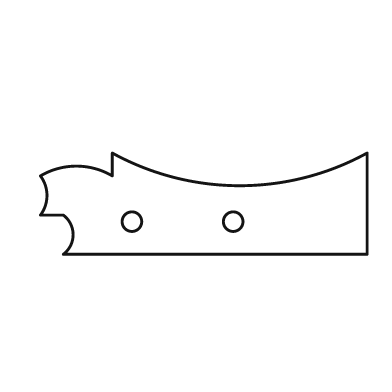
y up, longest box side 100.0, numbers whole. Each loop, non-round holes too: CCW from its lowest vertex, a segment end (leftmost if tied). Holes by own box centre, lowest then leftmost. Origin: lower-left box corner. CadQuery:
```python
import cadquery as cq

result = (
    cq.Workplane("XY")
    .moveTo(7.0, 0.0)
    .lineTo(100.0, 0.0)
    .lineTo(100.0, 31.0)
    .threePointArc((61.0, 21.0), (22.0, 31.0))
    .lineTo(22.0, 24.0)
    .threePointArc((11.0, 27.0), (0.0, 24.0))
    .threePointArc((2.0, 18.0), (0.0, 12.0))
    .lineTo(7.0, 12.0)
    .threePointArc((10.0, 6.0), (7.0, 0.0))
    .close()
    .moveTo(28.0, 10.0)
    .circle(3.0)
    .moveTo(59.0, 10.0)
    .circle(3.0)
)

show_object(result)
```